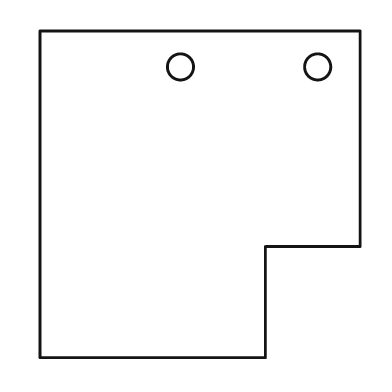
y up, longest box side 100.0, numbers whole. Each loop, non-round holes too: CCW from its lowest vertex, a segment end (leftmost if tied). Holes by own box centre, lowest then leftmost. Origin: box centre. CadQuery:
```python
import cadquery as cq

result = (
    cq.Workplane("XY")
    .moveTo(-49.0, -50.0)
    .lineTo(20.0, -50.0)
    .lineTo(20.0, -16.0)
    .lineTo(49.0, -16.0)
    .lineTo(49.0, 50.0)
    .lineTo(-49.0, 50.0)
    .close()
    .moveTo(-6.0, 39.0)
    .circle(4.0)
    .moveTo(36.0, 39.0)
    .circle(4.0)
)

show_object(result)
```